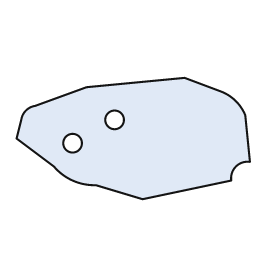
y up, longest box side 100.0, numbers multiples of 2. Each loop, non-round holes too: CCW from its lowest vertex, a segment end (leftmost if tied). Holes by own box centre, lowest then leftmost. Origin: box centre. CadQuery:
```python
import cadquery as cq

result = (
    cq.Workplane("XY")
    .moveTo(4.0, -26.0)
    .lineTo(42.0, -18.0)
    .threePointArc((44.0, -12.0), (50.0, -10.0))
    .lineTo(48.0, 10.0)
    .threePointArc((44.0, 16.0), (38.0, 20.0))
    .lineTo(22.0, 26.0)
    .lineTo(-20.0, 22.0)
    .lineTo(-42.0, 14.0)
    .threePointArc((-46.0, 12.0), (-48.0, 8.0))
    .lineTo(-50.0, 0.0)
    .lineTo(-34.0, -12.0)
    .threePointArc((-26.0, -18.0), (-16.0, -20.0))
    .close()
    .moveTo(-26.0, -2.0)
    .circle(4.0)
    .moveTo(-8.0, 8.0)
    .circle(4.0)
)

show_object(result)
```